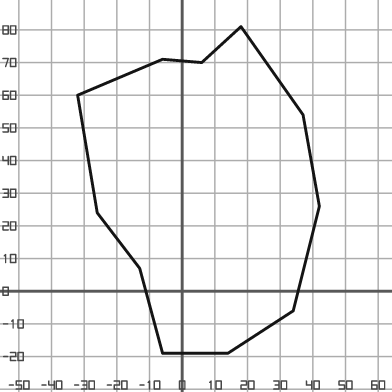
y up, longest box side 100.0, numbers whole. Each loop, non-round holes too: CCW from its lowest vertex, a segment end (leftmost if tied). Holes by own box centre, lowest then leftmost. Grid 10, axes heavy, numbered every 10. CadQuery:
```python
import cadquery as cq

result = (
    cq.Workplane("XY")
    .moveTo(-6.0, -19.0)
    .lineTo(14.0, -19.0)
    .lineTo(34.0, -6.0)
    .lineTo(42.0, 26.0)
    .lineTo(37.0, 54.0)
    .lineTo(18.0, 81.0)
    .lineTo(6.0, 70.0)
    .lineTo(-6.0, 71.0)
    .lineTo(-32.0, 60.0)
    .lineTo(-26.0, 24.0)
    .lineTo(-13.0, 7.0)
    .close()
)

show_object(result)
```